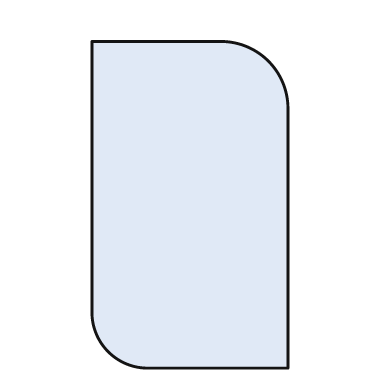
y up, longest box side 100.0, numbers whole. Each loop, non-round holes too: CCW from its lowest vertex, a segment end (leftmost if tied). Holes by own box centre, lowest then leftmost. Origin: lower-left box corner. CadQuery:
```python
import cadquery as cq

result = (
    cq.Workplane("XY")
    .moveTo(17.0, 0.0)
    .lineTo(60.0, 0.0)
    .lineTo(60.0, 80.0)
    .threePointArc((54.0, 94.0), (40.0, 100.0))
    .lineTo(0.0, 100.0)
    .lineTo(0.0, 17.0)
    .threePointArc((5.0, 5.0), (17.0, 0.0))
    .close()
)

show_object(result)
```